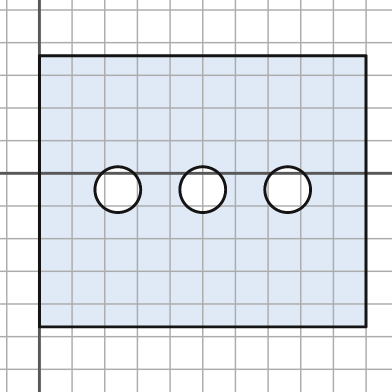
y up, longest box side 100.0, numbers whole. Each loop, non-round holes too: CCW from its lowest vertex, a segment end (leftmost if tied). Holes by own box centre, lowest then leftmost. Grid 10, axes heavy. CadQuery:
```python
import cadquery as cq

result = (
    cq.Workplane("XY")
    .moveTo(0.0, -47.0)
    .lineTo(100.0, -47.0)
    .lineTo(100.0, 36.0)
    .lineTo(0.0, 36.0)
    .close()
    .moveTo(24.0, -5.0)
    .circle(7.0)
    .moveTo(50.0, -5.0)
    .circle(7.0)
    .moveTo(76.0, -5.0)
    .circle(7.0)
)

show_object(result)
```